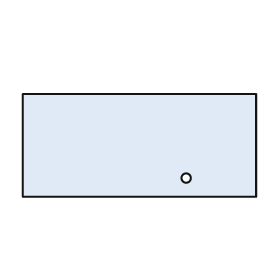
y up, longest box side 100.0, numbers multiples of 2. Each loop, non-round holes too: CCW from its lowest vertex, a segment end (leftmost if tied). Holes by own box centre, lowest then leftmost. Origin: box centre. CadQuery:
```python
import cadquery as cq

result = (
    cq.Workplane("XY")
    .moveTo(-50.0, -22.0)
    .lineTo(50.0, -22.0)
    .lineTo(50.0, 22.0)
    .lineTo(-50.0, 22.0)
    .close()
    .moveTo(20.0, -14.0)
    .circle(2.0)
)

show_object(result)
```